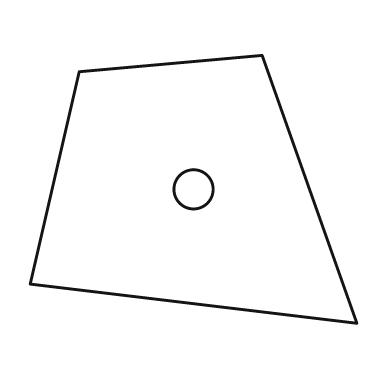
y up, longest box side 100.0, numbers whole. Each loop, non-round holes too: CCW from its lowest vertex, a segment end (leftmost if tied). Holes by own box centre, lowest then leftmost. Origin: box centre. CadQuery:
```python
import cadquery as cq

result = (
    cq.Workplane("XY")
    .moveTo(50.0, -41.0)
    .lineTo(21.0, 41.0)
    .lineTo(-35.0, 36.0)
    .lineTo(-50.0, -29.0)
    .close()
    .moveTo(0.0, 0.0)
    .circle(6.0)
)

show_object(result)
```